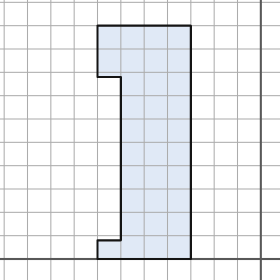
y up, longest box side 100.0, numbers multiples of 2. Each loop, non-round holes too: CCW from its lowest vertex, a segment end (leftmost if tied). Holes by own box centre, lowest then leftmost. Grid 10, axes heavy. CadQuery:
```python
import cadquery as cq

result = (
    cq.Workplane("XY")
    .moveTo(-70.0, 0.0)
    .lineTo(-30.0, 0.0)
    .lineTo(-30.0, 100.0)
    .lineTo(-70.0, 100.0)
    .lineTo(-70.0, 78.0)
    .lineTo(-60.0, 78.0)
    .lineTo(-60.0, 8.0)
    .lineTo(-70.0, 8.0)
    .close()
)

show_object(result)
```